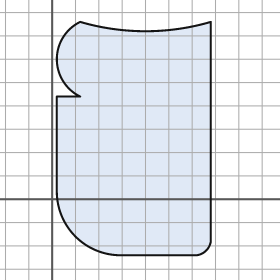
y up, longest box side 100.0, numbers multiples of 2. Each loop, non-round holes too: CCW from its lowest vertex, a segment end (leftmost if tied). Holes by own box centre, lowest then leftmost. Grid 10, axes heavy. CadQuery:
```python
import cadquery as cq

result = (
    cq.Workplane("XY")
    .moveTo(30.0, -24.0)
    .lineTo(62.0, -24.0)
    .threePointArc((66.0, -22.0), (68.0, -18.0))
    .lineTo(68.0, 76.0)
    .threePointArc((40.0, 72.0), (12.0, 76.0))
    .threePointArc((2.0, 60.0), (12.0, 44.0))
    .lineTo(2.0, 44.0)
    .lineTo(2.0, 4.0)
    .threePointArc((10.0, -16.0), (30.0, -24.0))
    .close()
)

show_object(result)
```